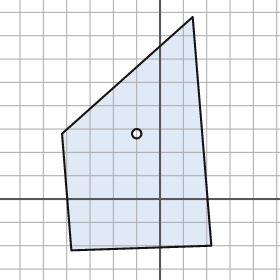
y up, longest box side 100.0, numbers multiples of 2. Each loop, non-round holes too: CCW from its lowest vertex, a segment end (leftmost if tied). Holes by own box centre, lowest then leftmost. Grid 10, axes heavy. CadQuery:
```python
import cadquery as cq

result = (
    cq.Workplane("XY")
    .moveTo(-38.0, -22.0)
    .lineTo(22.0, -20.0)
    .lineTo(14.0, 78.0)
    .lineTo(-42.0, 28.0)
    .close()
    .moveTo(-10.0, 28.0)
    .circle(2.0)
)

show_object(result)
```